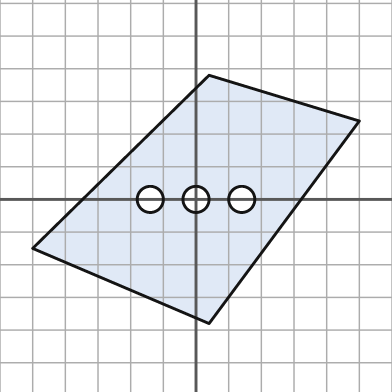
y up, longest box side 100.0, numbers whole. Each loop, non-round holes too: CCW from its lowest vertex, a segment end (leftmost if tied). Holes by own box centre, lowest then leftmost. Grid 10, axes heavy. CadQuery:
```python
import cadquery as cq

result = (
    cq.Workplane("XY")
    .moveTo(4.0, -38.0)
    .lineTo(50.0, 24.0)
    .lineTo(4.0, 38.0)
    .lineTo(-50.0, -15.0)
    .close()
    .moveTo(-14.0, 0.0)
    .circle(4.0)
    .moveTo(0.0, 0.0)
    .circle(4.0)
    .moveTo(14.0, 0.0)
    .circle(4.0)
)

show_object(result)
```